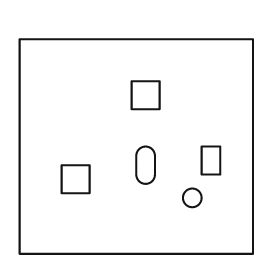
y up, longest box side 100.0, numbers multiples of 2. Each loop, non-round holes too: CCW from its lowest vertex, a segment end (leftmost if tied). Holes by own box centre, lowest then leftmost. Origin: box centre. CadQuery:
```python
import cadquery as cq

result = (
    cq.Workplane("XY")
    .moveTo(-50.0, -46.0)
    .lineTo(50.0, -46.0)
    .lineTo(50.0, 46.0)
    .lineTo(-50.0, 46.0)
    .close()
    .moveTo(24.0, -22.0)
    .circle(4.0)
    .moveTo(-32.0, -20.0)
    .lineTo(-20.0, -20.0)
    .lineTo(-20.0, -8.0)
    .lineTo(-32.0, -8.0)
    .close()
    .moveTo(0.0, -12.0)
    .threePointArc((4.0, -16.0), (8.0, -12.0))
    .lineTo(8.0, -4.0)
    .threePointArc((4.0, 0.0), (0.0, -4.0))
    .close()
    .moveTo(28.0, -12.0)
    .lineTo(36.0, -12.0)
    .lineTo(36.0, 0.0)
    .lineTo(28.0, 0.0)
    .close()
    .moveTo(-2.0, 16.0)
    .lineTo(10.0, 16.0)
    .lineTo(10.0, 28.0)
    .lineTo(-2.0, 28.0)
    .close()
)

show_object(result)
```